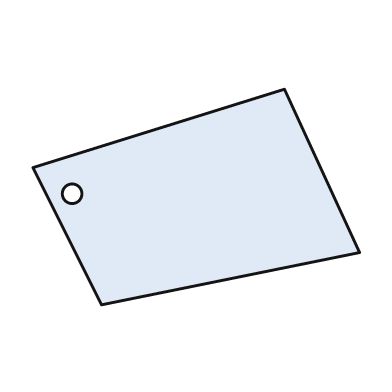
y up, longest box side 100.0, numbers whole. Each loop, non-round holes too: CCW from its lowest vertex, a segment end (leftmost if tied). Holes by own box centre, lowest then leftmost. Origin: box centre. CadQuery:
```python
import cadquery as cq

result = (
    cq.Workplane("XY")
    .moveTo(-29.0, -33.0)
    .lineTo(50.0, -17.0)
    .lineTo(27.0, 33.0)
    .lineTo(-50.0, 9.0)
    .close()
    .moveTo(-38.0, 1.0)
    .circle(3.0)
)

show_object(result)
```